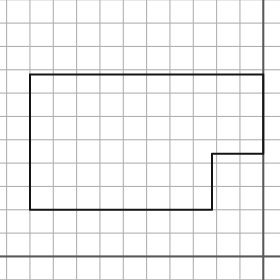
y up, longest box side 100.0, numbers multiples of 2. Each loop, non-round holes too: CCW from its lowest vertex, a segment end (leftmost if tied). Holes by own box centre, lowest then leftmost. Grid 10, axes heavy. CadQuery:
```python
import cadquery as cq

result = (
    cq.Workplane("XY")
    .moveTo(-100.0, 20.0)
    .lineTo(-22.0, 20.0)
    .lineTo(-22.0, 44.0)
    .lineTo(0.0, 44.0)
    .lineTo(0.0, 78.0)
    .lineTo(-100.0, 78.0)
    .close()
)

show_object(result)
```